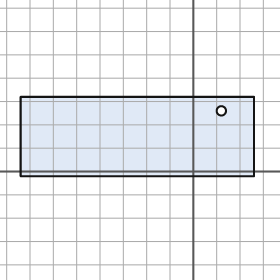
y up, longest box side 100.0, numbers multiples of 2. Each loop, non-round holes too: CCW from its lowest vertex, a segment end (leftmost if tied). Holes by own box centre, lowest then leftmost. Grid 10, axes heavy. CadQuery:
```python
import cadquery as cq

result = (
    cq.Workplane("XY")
    .moveTo(-74.0, -2.0)
    .lineTo(26.0, -2.0)
    .lineTo(26.0, 32.0)
    .lineTo(-74.0, 32.0)
    .close()
    .moveTo(12.0, 26.0)
    .circle(2.0)
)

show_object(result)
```